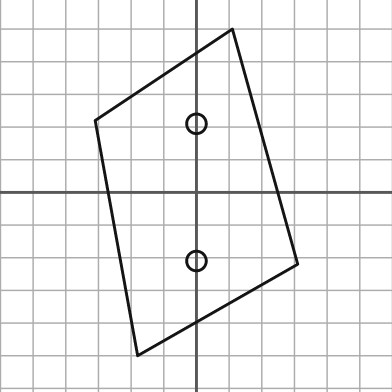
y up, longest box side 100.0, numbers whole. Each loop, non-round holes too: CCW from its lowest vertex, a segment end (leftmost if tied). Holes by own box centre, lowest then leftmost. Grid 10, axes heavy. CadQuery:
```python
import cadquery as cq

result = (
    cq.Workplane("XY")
    .moveTo(-18.0, -50.0)
    .lineTo(31.0, -22.0)
    .lineTo(11.0, 50.0)
    .lineTo(-31.0, 22.0)
    .close()
    .moveTo(0.0, -21.0)
    .circle(3.0)
    .moveTo(0.0, 21.0)
    .circle(3.0)
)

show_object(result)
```